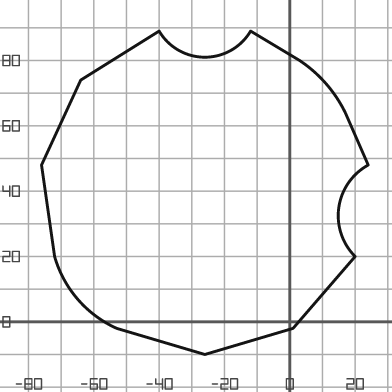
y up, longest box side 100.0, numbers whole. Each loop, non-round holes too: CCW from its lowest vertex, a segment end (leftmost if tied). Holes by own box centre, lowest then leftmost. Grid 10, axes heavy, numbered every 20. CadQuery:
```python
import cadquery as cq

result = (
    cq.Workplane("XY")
    .moveTo(-26.0, -10.0)
    .lineTo(1.0, -2.0)
    .lineTo(20.0, 20.0)
    .threePointArc((15.0, 35.0), (24.0, 48.0))
    .lineTo(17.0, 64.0)
    .threePointArc((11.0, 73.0), (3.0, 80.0))
    .lineTo(-12.0, 89.0)
    .threePointArc((-26.0, 81.0), (-40.0, 89.0))
    .lineTo(-64.0, 74.0)
    .lineTo(-76.0, 48.0)
    .lineTo(-72.0, 20.0)
    .threePointArc((-65.0, 7.0), (-53.0, -2.0))
    .close()
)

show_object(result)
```